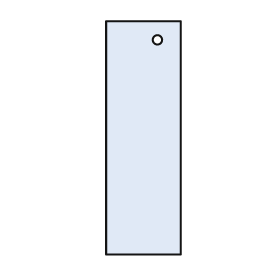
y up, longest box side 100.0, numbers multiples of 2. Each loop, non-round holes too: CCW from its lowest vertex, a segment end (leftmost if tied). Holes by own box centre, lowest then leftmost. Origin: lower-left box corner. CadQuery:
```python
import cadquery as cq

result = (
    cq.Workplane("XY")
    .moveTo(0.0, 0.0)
    .lineTo(32.0, 0.0)
    .lineTo(32.0, 100.0)
    .lineTo(0.0, 100.0)
    .close()
    .moveTo(22.0, 92.0)
    .circle(2.0)
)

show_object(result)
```